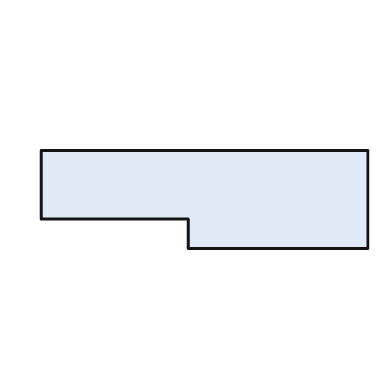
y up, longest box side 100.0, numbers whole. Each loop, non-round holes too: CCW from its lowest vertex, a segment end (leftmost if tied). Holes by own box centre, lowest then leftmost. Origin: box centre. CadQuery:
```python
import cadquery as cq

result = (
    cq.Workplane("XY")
    .moveTo(-5.0, -15.0)
    .lineTo(50.0, -15.0)
    .lineTo(50.0, 15.0)
    .lineTo(-50.0, 15.0)
    .lineTo(-50.0, -6.0)
    .lineTo(-5.0, -6.0)
    .close()
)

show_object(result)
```